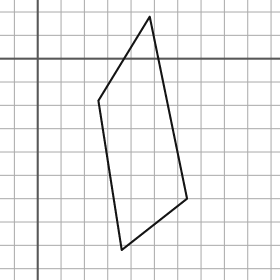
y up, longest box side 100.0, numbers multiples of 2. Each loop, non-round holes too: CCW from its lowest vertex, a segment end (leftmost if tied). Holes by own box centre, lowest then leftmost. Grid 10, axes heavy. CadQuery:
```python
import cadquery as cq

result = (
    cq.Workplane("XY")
    .moveTo(36.0, -82.0)
    .lineTo(64.0, -60.0)
    .lineTo(48.0, 18.0)
    .lineTo(26.0, -18.0)
    .close()
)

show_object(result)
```